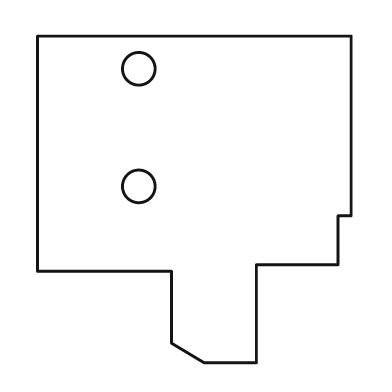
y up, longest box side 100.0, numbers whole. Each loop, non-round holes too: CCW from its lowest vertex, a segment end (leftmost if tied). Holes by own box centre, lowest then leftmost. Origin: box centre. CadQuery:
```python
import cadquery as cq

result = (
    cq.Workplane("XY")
    .moveTo(3.0, -50.0)
    .lineTo(19.0, -50.0)
    .lineTo(19.0, -20.0)
    .lineTo(44.0, -20.0)
    .lineTo(44.0, -5.0)
    .lineTo(48.0, -5.0)
    .lineTo(48.0, 50.0)
    .lineTo(-48.0, 50.0)
    .lineTo(-48.0, -22.0)
    .lineTo(-7.0, -22.0)
    .lineTo(-7.0, -44.0)
    .close()
    .moveTo(-17.0, 4.0)
    .circle(5.0)
    .moveTo(-17.0, 40.0)
    .circle(5.0)
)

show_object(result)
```